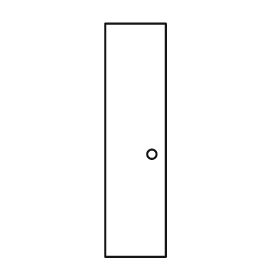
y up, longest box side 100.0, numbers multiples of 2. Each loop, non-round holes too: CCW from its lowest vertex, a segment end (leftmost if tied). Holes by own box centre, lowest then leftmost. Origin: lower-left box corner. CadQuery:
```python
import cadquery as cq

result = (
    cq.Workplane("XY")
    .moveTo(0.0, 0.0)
    .lineTo(26.0, 0.0)
    .lineTo(26.0, 100.0)
    .lineTo(0.0, 100.0)
    .close()
    .moveTo(20.0, 44.0)
    .circle(2.0)
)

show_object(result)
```